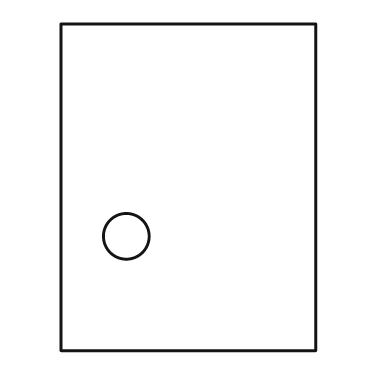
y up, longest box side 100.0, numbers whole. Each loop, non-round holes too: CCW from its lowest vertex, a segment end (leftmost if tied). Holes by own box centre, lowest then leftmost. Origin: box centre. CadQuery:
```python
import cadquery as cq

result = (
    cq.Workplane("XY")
    .moveTo(-39.0, -50.0)
    .lineTo(39.0, -50.0)
    .lineTo(39.0, 50.0)
    .lineTo(-39.0, 50.0)
    .close()
    .moveTo(-19.0, -15.0)
    .circle(7.0)
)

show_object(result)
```